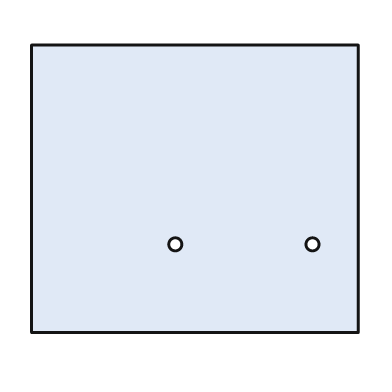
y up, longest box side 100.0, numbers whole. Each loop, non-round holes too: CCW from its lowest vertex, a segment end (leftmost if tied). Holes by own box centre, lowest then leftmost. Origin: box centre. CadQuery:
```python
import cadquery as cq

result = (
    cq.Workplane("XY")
    .moveTo(-50.0, -44.0)
    .lineTo(50.0, -44.0)
    .lineTo(50.0, 44.0)
    .lineTo(-50.0, 44.0)
    .close()
    .moveTo(-6.0, -17.0)
    .circle(2.0)
    .moveTo(36.0, -17.0)
    .circle(2.0)
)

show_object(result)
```